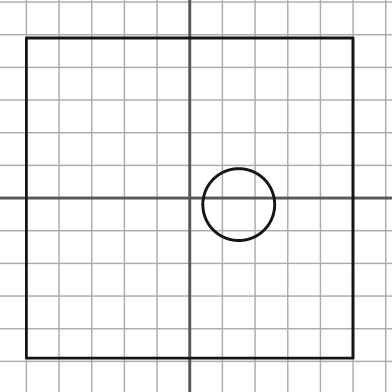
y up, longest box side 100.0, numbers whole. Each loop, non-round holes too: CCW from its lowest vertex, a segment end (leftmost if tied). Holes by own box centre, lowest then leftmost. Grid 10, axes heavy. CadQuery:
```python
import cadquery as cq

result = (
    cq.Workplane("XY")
    .moveTo(-50.0, -49.0)
    .lineTo(50.0, -49.0)
    .lineTo(50.0, 49.0)
    .lineTo(-50.0, 49.0)
    .close()
    .moveTo(15.0, -2.0)
    .circle(11.0)
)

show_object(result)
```